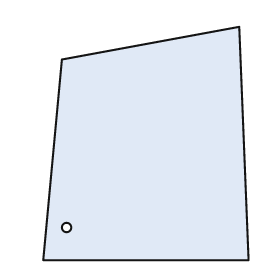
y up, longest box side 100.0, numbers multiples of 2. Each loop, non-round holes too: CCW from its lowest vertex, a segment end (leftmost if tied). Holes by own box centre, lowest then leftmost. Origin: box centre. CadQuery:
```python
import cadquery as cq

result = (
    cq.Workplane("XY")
    .moveTo(-44.0, -50.0)
    .lineTo(44.0, -50.0)
    .lineTo(40.0, 50.0)
    .lineTo(-36.0, 36.0)
    .close()
    .moveTo(-34.0, -36.0)
    .circle(2.0)
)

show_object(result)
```